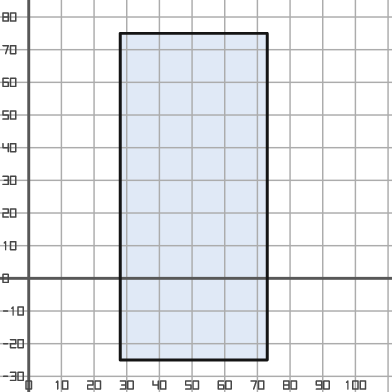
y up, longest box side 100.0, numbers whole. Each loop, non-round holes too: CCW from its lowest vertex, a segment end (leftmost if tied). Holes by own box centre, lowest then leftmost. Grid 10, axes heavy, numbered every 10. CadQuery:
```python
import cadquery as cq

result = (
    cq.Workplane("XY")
    .moveTo(28.0, -25.0)
    .lineTo(73.0, -25.0)
    .lineTo(73.0, 75.0)
    .lineTo(28.0, 75.0)
    .close()
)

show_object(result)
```